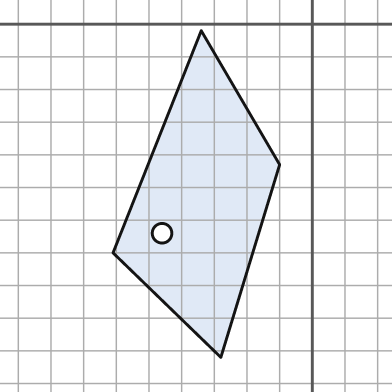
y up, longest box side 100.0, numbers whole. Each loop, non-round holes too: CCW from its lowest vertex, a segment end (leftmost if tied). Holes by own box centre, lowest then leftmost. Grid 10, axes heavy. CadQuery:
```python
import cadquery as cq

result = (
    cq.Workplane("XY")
    .moveTo(-28.0, -102.0)
    .lineTo(-10.0, -43.0)
    .lineTo(-34.0, -2.0)
    .lineTo(-61.0, -70.0)
    .close()
    .moveTo(-46.0, -64.0)
    .circle(3.0)
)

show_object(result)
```